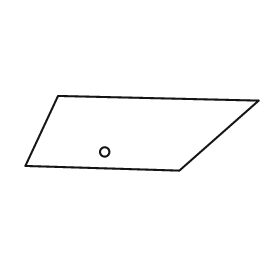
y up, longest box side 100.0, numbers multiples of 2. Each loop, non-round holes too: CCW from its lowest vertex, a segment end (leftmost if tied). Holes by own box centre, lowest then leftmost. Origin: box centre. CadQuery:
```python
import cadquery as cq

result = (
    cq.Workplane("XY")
    .moveTo(16.0, -16.0)
    .lineTo(50.0, 14.0)
    .lineTo(-36.0, 16.0)
    .lineTo(-50.0, -14.0)
    .close()
    .moveTo(-16.0, -8.0)
    .circle(2.0)
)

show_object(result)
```